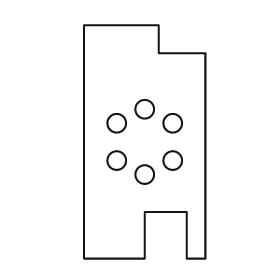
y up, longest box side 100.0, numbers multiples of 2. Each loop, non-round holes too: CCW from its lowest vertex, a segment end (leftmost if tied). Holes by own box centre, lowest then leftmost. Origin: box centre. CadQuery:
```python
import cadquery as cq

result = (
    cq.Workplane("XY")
    .moveTo(-26.0, -50.0)
    .lineTo(0.0, -50.0)
    .lineTo(0.0, -30.0)
    .lineTo(18.0, -30.0)
    .lineTo(18.0, -50.0)
    .lineTo(26.0, -50.0)
    .lineTo(26.0, 38.0)
    .lineTo(6.0, 38.0)
    .lineTo(6.0, 50.0)
    .lineTo(-26.0, 50.0)
    .close()
    .moveTo(0.0, -14.0)
    .circle(4.0)
    .moveTo(-12.0, -8.0)
    .circle(4.0)
    .moveTo(12.0, -8.0)
    .circle(4.0)
    .moveTo(-12.0, 8.0)
    .circle(4.0)
    .moveTo(12.0, 8.0)
    .circle(4.0)
    .moveTo(0.0, 14.0)
    .circle(4.0)
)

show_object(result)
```